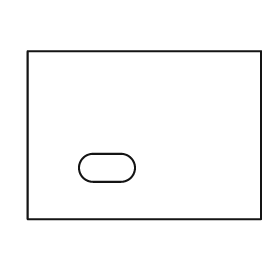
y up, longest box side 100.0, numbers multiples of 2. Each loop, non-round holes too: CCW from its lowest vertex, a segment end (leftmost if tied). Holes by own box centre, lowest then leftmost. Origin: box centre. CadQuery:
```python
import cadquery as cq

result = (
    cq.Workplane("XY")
    .moveTo(-50.0, -36.0)
    .lineTo(50.0, -36.0)
    .lineTo(50.0, 36.0)
    .lineTo(-50.0, 36.0)
    .close()
    .moveTo(-22.0, -20.0)
    .lineTo(-10.0, -20.0)
    .threePointArc((-4.0, -14.0), (-10.0, -8.0))
    .lineTo(-22.0, -8.0)
    .threePointArc((-28.0, -14.0), (-22.0, -20.0))
    .close()
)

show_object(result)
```